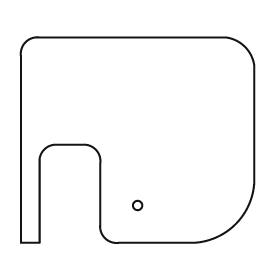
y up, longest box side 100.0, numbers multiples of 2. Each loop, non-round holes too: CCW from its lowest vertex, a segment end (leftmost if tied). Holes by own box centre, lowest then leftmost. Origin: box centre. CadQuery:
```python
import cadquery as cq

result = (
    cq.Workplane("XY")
    .moveTo(-50.0, -44.0)
    .lineTo(-42.0, -44.0)
    .lineTo(-42.0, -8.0)
    .threePointArc((-40.0, -4.0), (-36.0, -2.0))
    .lineTo(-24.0, -2.0)
    .threePointArc((-18.0, -4.0), (-16.0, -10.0))
    .lineTo(-16.0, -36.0)
    .threePointArc((-14.0, -42.0), (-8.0, -44.0))
    .lineTo(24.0, -44.0)
    .threePointArc((42.0, -36.0), (50.0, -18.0))
    .lineTo(50.0, 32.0)
    .threePointArc((46.0, 40.0), (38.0, 44.0))
    .lineTo(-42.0, 44.0)
    .threePointArc((-48.0, 42.0), (-50.0, 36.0))
    .close()
    .moveTo(0.0, -28.0)
    .circle(2.0)
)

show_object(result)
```